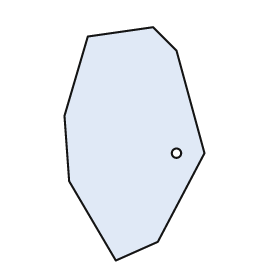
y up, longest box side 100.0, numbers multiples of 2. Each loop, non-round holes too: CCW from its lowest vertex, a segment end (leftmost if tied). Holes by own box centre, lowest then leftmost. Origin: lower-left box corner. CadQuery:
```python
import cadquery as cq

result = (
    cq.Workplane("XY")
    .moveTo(22.0, 0.0)
    .lineTo(40.0, 8.0)
    .lineTo(60.0, 46.0)
    .lineTo(48.0, 90.0)
    .lineTo(38.0, 100.0)
    .lineTo(10.0, 96.0)
    .lineTo(0.0, 62.0)
    .lineTo(2.0, 34.0)
    .close()
    .moveTo(48.0, 46.0)
    .circle(2.0)
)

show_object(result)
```